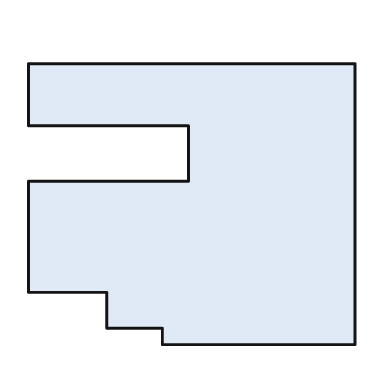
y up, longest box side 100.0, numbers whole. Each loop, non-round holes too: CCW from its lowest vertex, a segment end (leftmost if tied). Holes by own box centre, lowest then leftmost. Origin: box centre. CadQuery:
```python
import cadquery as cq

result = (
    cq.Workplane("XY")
    .moveTo(-9.0, -43.0)
    .lineTo(50.0, -43.0)
    .lineTo(50.0, 43.0)
    .lineTo(-50.0, 43.0)
    .lineTo(-50.0, 24.0)
    .lineTo(-1.0, 24.0)
    .lineTo(-1.0, 7.0)
    .lineTo(-50.0, 7.0)
    .lineTo(-50.0, -27.0)
    .lineTo(-26.0, -27.0)
    .lineTo(-26.0, -38.0)
    .lineTo(-9.0, -38.0)
    .close()
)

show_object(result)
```